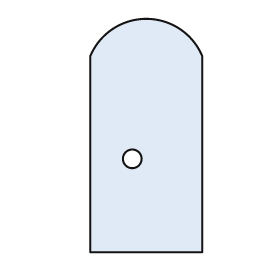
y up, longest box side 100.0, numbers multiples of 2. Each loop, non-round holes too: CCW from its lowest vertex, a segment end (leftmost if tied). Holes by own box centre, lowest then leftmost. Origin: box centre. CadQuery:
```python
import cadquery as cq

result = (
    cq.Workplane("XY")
    .moveTo(-24.0, -50.0)
    .lineTo(24.0, -50.0)
    .lineTo(24.0, 34.0)
    .threePointArc((0.0, 50.0), (-24.0, 34.0))
    .close()
    .moveTo(-6.0, -10.0)
    .circle(4.0)
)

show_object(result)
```